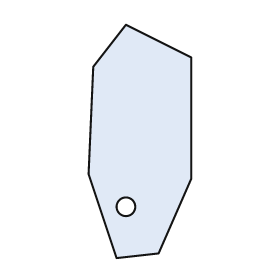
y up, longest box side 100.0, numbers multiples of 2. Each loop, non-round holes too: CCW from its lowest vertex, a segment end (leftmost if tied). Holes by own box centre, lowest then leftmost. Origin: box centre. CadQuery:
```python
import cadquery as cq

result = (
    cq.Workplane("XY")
    .moveTo(-10.0, -50.0)
    .lineTo(8.0, -48.0)
    .lineTo(22.0, -16.0)
    .lineTo(22.0, 36.0)
    .lineTo(-6.0, 50.0)
    .lineTo(-20.0, 32.0)
    .lineTo(-22.0, -14.0)
    .close()
    .moveTo(-6.0, -28.0)
    .circle(4.0)
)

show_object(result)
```